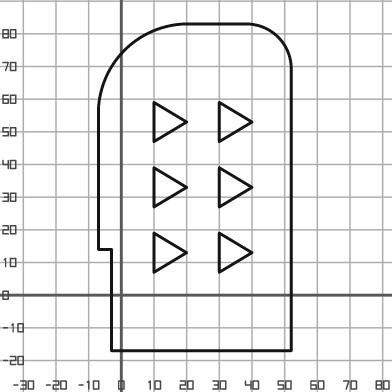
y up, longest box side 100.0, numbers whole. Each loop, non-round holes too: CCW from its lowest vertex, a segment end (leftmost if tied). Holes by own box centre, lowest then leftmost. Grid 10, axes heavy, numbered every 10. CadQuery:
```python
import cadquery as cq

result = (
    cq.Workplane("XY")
    .moveTo(-3.0, -17.0)
    .lineTo(52.0, -17.0)
    .lineTo(52.0, 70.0)
    .threePointArc((48.0, 79.0), (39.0, 83.0))
    .lineTo(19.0, 83.0)
    .threePointArc((1.0, 75.0), (-7.0, 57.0))
    .lineTo(-7.0, 14.0)
    .lineTo(-3.0, 14.0)
    .close()
    .moveTo(10.0, 7.0)
    .lineTo(20.0, 13.0)
    .lineTo(10.0, 19.0)
    .close()
    .moveTo(30.0, 7.0)
    .lineTo(40.0, 13.0)
    .lineTo(30.0, 19.0)
    .close()
    .moveTo(10.0, 27.0)
    .lineTo(20.0, 33.0)
    .lineTo(10.0, 39.0)
    .close()
    .moveTo(30.0, 27.0)
    .lineTo(40.0, 33.0)
    .lineTo(30.0, 39.0)
    .close()
    .moveTo(10.0, 47.0)
    .lineTo(20.0, 53.0)
    .lineTo(10.0, 59.0)
    .close()
    .moveTo(30.0, 47.0)
    .lineTo(40.0, 53.0)
    .lineTo(30.0, 59.0)
    .close()
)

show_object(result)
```